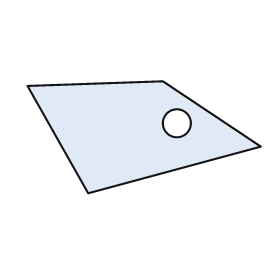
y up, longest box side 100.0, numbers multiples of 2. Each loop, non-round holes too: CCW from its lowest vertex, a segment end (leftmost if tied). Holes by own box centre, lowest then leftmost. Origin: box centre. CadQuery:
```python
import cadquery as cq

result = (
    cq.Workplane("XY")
    .moveTo(-24.0, -24.0)
    .lineTo(50.0, -4.0)
    .lineTo(8.0, 24.0)
    .lineTo(-50.0, 22.0)
    .close()
    .moveTo(14.0, 6.0)
    .circle(6.0)
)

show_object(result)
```